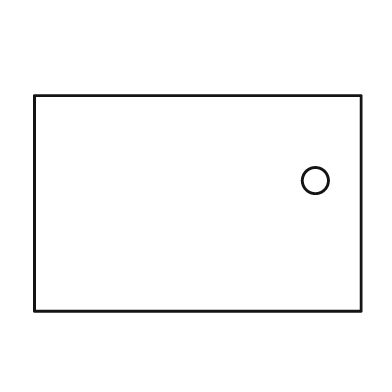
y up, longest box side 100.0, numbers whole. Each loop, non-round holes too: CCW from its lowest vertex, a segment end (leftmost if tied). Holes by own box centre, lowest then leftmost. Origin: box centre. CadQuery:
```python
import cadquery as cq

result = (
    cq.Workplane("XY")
    .moveTo(-50.0, -33.0)
    .lineTo(50.0, -33.0)
    .lineTo(50.0, 33.0)
    .lineTo(-50.0, 33.0)
    .close()
    .moveTo(36.0, 7.0)
    .circle(4.0)
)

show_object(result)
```